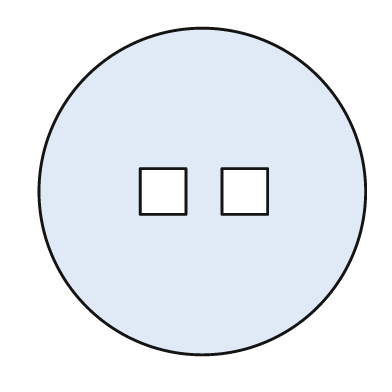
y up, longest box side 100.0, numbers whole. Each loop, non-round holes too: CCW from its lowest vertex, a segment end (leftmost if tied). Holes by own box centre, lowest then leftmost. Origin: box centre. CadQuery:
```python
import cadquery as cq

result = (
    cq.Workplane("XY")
    .moveTo(0.0, 0.0)
    .circle(50.0)
    .moveTo(-19.0, -7.0)
    .lineTo(-5.0, -7.0)
    .lineTo(-5.0, 7.0)
    .lineTo(-19.0, 7.0)
    .close()
    .moveTo(6.0, -7.0)
    .lineTo(20.0, -7.0)
    .lineTo(20.0, 7.0)
    .lineTo(6.0, 7.0)
    .close()
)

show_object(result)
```